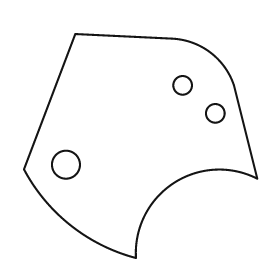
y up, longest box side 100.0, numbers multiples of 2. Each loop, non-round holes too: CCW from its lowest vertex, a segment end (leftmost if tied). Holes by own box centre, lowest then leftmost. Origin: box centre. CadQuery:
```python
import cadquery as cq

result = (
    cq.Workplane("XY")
    .moveTo(-2.0, -48.0)
    .threePointArc((14.0, -16.0), (50.0, -14.0))
    .lineTo(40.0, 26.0)
    .threePointArc((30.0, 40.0), (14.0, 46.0))
    .lineTo(-28.0, 48.0)
    .lineTo(-50.0, -10.0)
    .threePointArc((-30.0, -34.0), (-2.0, -48.0))
    .close()
    .moveTo(-32.0, -8.0)
    .circle(6.0)
    .moveTo(32.0, 14.0)
    .circle(4.0)
    .moveTo(18.0, 26.0)
    .circle(4.0)
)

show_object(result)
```